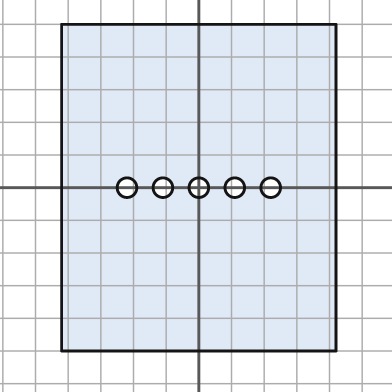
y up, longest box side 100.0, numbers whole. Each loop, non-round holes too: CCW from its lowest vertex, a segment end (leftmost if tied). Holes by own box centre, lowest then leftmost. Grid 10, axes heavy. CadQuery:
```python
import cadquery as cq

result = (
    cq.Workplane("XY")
    .moveTo(-42.0, -50.0)
    .lineTo(42.0, -50.0)
    .lineTo(42.0, 50.0)
    .lineTo(-42.0, 50.0)
    .close()
    .moveTo(-22.0, 0.0)
    .circle(3.0)
    .moveTo(-11.0, 0.0)
    .circle(3.0)
    .moveTo(0.0, 0.0)
    .circle(3.0)
    .moveTo(11.0, 0.0)
    .circle(3.0)
    .moveTo(22.0, 0.0)
    .circle(3.0)
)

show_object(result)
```